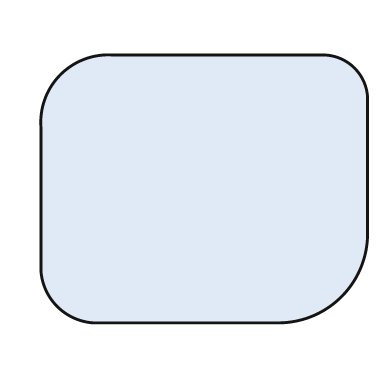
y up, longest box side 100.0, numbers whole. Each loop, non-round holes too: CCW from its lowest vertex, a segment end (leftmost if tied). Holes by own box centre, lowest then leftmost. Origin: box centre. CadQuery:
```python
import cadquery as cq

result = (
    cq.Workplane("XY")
    .moveTo(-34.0, -41.0)
    .lineTo(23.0, -41.0)
    .threePointArc((42.0, -33.0), (50.0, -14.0))
    .lineTo(50.0, 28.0)
    .threePointArc((46.0, 37.0), (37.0, 41.0))
    .lineTo(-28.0, 41.0)
    .threePointArc((-44.0, 35.0), (-50.0, 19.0))
    .lineTo(-50.0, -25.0)
    .threePointArc((-45.0, -36.0), (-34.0, -41.0))
    .close()
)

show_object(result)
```